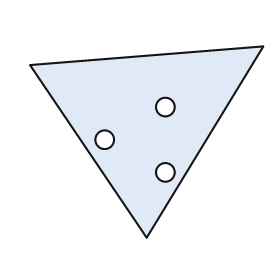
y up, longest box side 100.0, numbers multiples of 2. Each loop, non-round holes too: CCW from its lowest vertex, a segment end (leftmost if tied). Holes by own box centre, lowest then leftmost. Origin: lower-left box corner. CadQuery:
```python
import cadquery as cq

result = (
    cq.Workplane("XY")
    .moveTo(50.0, 0.0)
    .lineTo(100.0, 82.0)
    .lineTo(0.0, 74.0)
    .close()
    .moveTo(58.0, 28.0)
    .circle(4.0)
    .moveTo(32.0, 42.0)
    .circle(4.0)
    .moveTo(58.0, 56.0)
    .circle(4.0)
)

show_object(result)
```